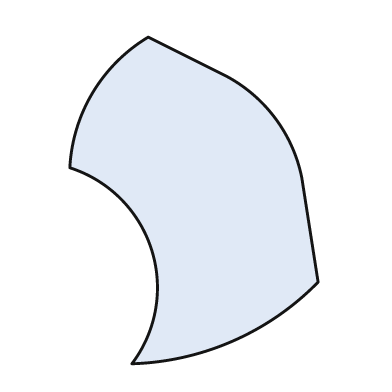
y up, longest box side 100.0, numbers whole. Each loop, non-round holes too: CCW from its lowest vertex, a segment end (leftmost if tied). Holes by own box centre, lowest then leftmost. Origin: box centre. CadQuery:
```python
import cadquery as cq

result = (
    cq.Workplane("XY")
    .moveTo(-19.0, -50.0)
    .threePointArc((12.0, -43.0), (38.0, -25.0))
    .lineTo(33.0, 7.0)
    .threePointArc((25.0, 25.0), (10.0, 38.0))
    .lineTo(-14.0, 50.0)
    .threePointArc((-31.0, 33.0), (-38.0, 10.0))
    .threePointArc((-13.0, -15.0), (-19.0, -50.0))
    .close()
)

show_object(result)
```